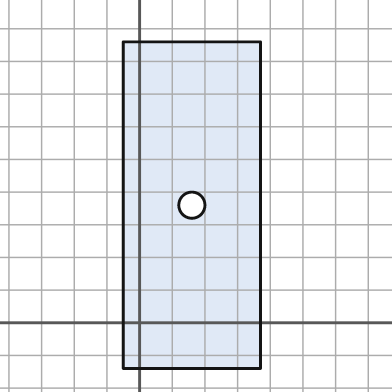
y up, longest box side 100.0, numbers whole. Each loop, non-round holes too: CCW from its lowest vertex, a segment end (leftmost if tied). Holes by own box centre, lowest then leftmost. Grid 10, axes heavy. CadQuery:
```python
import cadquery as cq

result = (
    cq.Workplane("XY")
    .moveTo(-5.0, -14.0)
    .lineTo(37.0, -14.0)
    .lineTo(37.0, 86.0)
    .lineTo(-5.0, 86.0)
    .close()
    .moveTo(16.0, 36.0)
    .circle(4.0)
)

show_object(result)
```